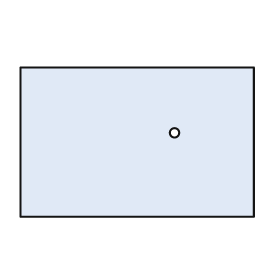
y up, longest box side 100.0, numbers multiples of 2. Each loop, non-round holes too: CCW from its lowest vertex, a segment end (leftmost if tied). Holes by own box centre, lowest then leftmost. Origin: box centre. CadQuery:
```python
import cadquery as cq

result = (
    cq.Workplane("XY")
    .moveTo(-50.0, -32.0)
    .lineTo(50.0, -32.0)
    .lineTo(50.0, 32.0)
    .lineTo(-50.0, 32.0)
    .close()
    .moveTo(16.0, 4.0)
    .circle(2.0)
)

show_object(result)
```